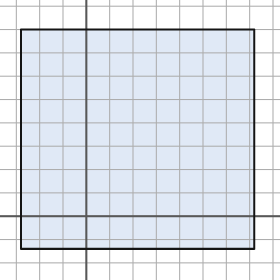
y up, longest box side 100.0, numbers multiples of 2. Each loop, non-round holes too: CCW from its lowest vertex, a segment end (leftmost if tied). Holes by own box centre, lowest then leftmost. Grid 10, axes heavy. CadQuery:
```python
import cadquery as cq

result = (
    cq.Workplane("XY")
    .moveTo(-28.0, -14.0)
    .lineTo(72.0, -14.0)
    .lineTo(72.0, 80.0)
    .lineTo(-28.0, 80.0)
    .close()
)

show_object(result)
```